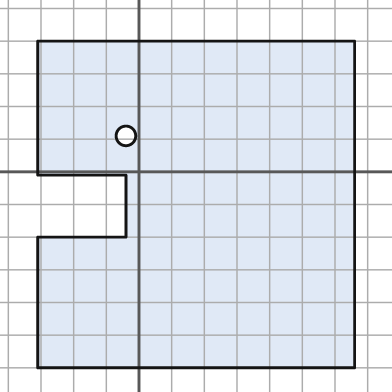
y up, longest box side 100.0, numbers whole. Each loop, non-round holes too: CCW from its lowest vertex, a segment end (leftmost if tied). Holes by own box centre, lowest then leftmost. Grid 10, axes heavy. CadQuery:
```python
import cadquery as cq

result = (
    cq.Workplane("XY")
    .moveTo(-31.0, -60.0)
    .lineTo(66.0, -60.0)
    .lineTo(66.0, 40.0)
    .lineTo(-31.0, 40.0)
    .lineTo(-31.0, -1.0)
    .lineTo(-4.0, -1.0)
    .lineTo(-4.0, -20.0)
    .lineTo(-31.0, -20.0)
    .close()
    .moveTo(-4.0, 11.0)
    .circle(3.0)
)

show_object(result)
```